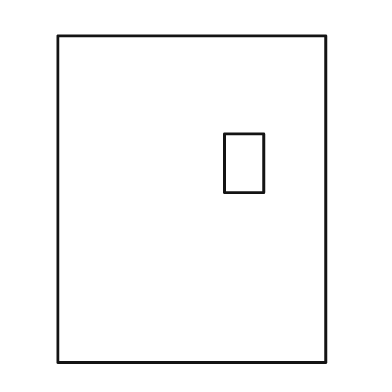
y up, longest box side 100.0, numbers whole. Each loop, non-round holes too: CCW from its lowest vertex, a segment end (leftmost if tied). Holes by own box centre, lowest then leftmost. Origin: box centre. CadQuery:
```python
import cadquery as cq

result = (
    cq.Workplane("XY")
    .moveTo(-41.0, -50.0)
    .lineTo(41.0, -50.0)
    .lineTo(41.0, 50.0)
    .lineTo(-41.0, 50.0)
    .close()
    .moveTo(10.0, 2.0)
    .lineTo(22.0, 2.0)
    .lineTo(22.0, 20.0)
    .lineTo(10.0, 20.0)
    .close()
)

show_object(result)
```